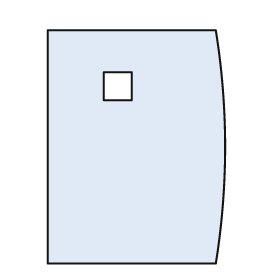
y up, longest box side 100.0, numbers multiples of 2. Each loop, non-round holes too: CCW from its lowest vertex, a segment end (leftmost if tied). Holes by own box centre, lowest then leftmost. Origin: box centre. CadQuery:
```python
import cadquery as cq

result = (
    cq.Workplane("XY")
    .moveTo(-38.0, -50.0)
    .lineTo(34.0, -50.0)
    .threePointArc((38.0, 0.0), (34.0, 50.0))
    .lineTo(-38.0, 50.0)
    .close()
    .moveTo(-14.0, 20.0)
    .lineTo(-2.0, 20.0)
    .lineTo(-2.0, 32.0)
    .lineTo(-14.0, 32.0)
    .close()
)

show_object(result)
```